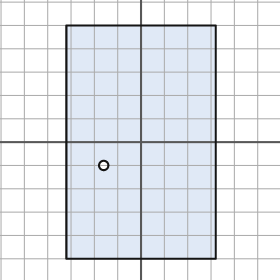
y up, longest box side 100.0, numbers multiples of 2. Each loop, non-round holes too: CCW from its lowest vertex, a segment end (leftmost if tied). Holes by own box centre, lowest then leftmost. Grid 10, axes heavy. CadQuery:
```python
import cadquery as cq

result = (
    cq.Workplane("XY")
    .moveTo(-32.0, -50.0)
    .lineTo(32.0, -50.0)
    .lineTo(32.0, 50.0)
    .lineTo(-32.0, 50.0)
    .close()
    .moveTo(-16.0, -10.0)
    .circle(2.0)
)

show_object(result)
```